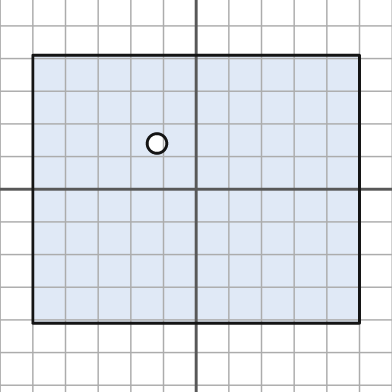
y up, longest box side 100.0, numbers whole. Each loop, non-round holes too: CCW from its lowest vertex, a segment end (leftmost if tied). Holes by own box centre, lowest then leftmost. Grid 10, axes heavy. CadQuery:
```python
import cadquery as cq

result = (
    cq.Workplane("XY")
    .moveTo(-50.0, -41.0)
    .lineTo(50.0, -41.0)
    .lineTo(50.0, 41.0)
    .lineTo(-50.0, 41.0)
    .close()
    .moveTo(-12.0, 14.0)
    .circle(3.0)
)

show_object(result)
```